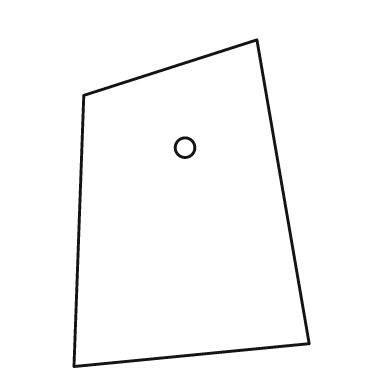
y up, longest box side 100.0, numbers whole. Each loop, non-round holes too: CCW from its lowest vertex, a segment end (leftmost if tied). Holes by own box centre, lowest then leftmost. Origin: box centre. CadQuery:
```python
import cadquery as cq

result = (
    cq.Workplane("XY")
    .moveTo(-36.0, -50.0)
    .lineTo(36.0, -43.0)
    .lineTo(20.0, 50.0)
    .lineTo(-33.0, 33.0)
    .close()
    .moveTo(-2.0, 17.0)
    .circle(3.0)
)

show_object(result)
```